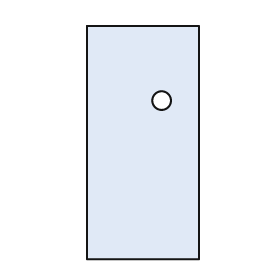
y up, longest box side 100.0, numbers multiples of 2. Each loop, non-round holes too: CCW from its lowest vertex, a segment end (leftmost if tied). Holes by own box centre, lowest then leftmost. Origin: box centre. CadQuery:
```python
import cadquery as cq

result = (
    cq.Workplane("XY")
    .moveTo(-24.0, -50.0)
    .lineTo(24.0, -50.0)
    .lineTo(24.0, 50.0)
    .lineTo(-24.0, 50.0)
    .close()
    .moveTo(8.0, 18.0)
    .circle(4.0)
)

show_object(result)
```